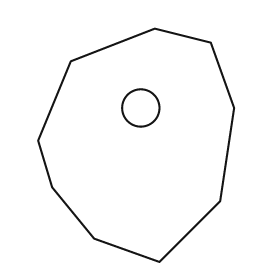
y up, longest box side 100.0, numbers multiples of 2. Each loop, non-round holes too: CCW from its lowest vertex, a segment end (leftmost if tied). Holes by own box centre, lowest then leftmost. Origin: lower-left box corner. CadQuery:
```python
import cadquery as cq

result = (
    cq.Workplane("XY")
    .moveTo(52.0, 0.0)
    .lineTo(78.0, 26.0)
    .lineTo(84.0, 66.0)
    .lineTo(74.0, 94.0)
    .lineTo(50.0, 100.0)
    .lineTo(14.0, 86.0)
    .lineTo(0.0, 52.0)
    .lineTo(6.0, 32.0)
    .lineTo(24.0, 10.0)
    .close()
    .moveTo(44.0, 66.0)
    .circle(8.0)
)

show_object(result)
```